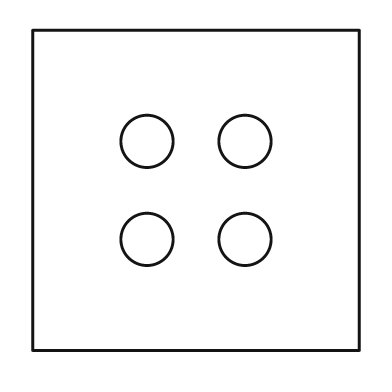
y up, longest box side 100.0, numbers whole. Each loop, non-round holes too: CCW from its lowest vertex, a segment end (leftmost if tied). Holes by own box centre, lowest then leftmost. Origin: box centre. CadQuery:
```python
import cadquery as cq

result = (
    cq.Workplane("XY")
    .moveTo(-50.0, -49.0)
    .lineTo(50.0, -49.0)
    .lineTo(50.0, 49.0)
    .lineTo(-50.0, 49.0)
    .close()
    .moveTo(-15.0, -15.0)
    .circle(8.0)
    .moveTo(15.0, -15.0)
    .circle(8.0)
    .moveTo(-15.0, 15.0)
    .circle(8.0)
    .moveTo(15.0, 15.0)
    .circle(8.0)
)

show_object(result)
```